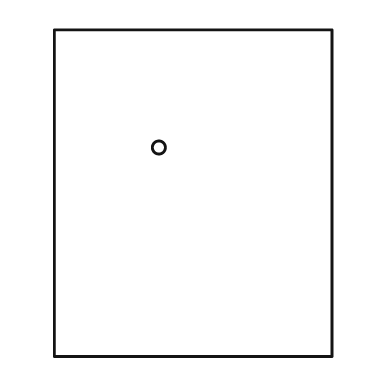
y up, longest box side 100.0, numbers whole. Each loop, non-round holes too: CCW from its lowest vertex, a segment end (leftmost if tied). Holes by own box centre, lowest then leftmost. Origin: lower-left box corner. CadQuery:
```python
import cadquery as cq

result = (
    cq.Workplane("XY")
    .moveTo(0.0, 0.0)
    .lineTo(85.0, 0.0)
    .lineTo(85.0, 100.0)
    .lineTo(0.0, 100.0)
    .close()
    .moveTo(32.0, 64.0)
    .circle(2.0)
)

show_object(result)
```